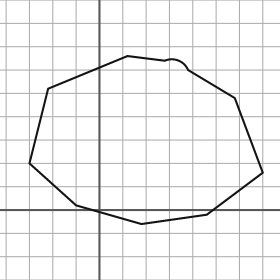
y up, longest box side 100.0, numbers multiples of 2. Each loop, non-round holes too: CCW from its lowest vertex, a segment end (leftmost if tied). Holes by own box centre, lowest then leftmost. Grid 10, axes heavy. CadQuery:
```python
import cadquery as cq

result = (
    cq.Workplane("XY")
    .moveTo(18.0, -6.0)
    .lineTo(46.0, -2.0)
    .lineTo(70.0, 16.0)
    .lineTo(58.0, 48.0)
    .lineTo(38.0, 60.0)
    .threePointArc((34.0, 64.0), (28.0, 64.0))
    .lineTo(12.0, 66.0)
    .lineTo(-22.0, 52.0)
    .lineTo(-30.0, 20.0)
    .lineTo(-10.0, 2.0)
    .close()
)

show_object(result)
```